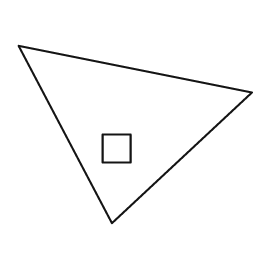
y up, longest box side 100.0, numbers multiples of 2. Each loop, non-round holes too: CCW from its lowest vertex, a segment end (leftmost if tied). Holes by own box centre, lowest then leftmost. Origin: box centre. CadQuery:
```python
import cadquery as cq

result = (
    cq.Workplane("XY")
    .moveTo(-10.0, -38.0)
    .lineTo(50.0, 18.0)
    .lineTo(-50.0, 38.0)
    .close()
    .moveTo(-14.0, -12.0)
    .lineTo(-2.0, -12.0)
    .lineTo(-2.0, 0.0)
    .lineTo(-14.0, 0.0)
    .close()
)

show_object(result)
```